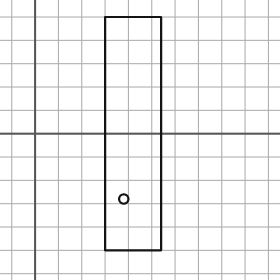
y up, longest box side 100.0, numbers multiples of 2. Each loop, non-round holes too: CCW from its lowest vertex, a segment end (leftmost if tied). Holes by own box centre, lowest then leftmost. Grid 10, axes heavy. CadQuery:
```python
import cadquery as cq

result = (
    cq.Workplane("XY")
    .moveTo(30.0, -50.0)
    .lineTo(54.0, -50.0)
    .lineTo(54.0, 50.0)
    .lineTo(30.0, 50.0)
    .close()
    .moveTo(38.0, -28.0)
    .circle(2.0)
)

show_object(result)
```